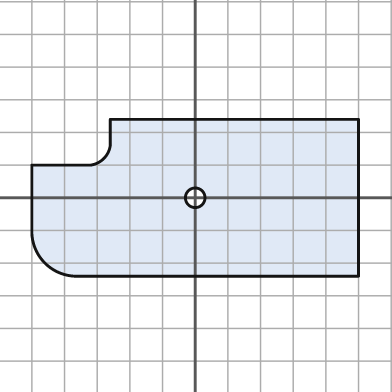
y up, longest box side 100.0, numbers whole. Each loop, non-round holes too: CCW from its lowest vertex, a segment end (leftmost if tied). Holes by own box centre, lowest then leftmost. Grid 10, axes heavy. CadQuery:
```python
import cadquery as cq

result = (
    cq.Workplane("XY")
    .moveTo(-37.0, -24.0)
    .lineTo(50.0, -24.0)
    .lineTo(50.0, 24.0)
    .lineTo(-26.0, 24.0)
    .lineTo(-26.0, 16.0)
    .threePointArc((-28.0, 12.0), (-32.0, 10.0))
    .lineTo(-50.0, 10.0)
    .lineTo(-50.0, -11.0)
    .threePointArc((-46.0, -20.0), (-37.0, -24.0))
    .close()
    .moveTo(0.0, 0.0)
    .circle(3.0)
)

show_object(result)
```